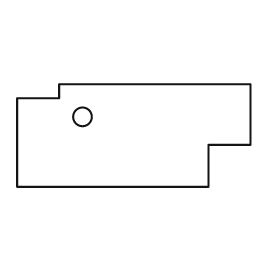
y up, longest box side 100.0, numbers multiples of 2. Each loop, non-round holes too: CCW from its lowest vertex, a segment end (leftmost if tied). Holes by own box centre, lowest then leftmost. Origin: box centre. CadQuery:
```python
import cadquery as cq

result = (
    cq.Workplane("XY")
    .moveTo(-50.0, -22.0)
    .lineTo(32.0, -22.0)
    .lineTo(32.0, -4.0)
    .lineTo(50.0, -4.0)
    .lineTo(50.0, 22.0)
    .lineTo(-32.0, 22.0)
    .lineTo(-32.0, 16.0)
    .lineTo(-50.0, 16.0)
    .close()
    .moveTo(-22.0, 8.0)
    .circle(4.0)
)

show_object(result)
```